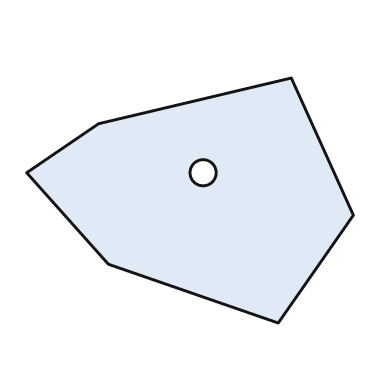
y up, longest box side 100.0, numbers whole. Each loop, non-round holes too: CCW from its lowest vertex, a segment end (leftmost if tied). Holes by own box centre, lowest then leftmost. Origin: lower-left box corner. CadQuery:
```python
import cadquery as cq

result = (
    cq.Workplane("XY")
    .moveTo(77.0, 0.0)
    .lineTo(100.0, 33.0)
    .lineTo(81.0, 75.0)
    .lineTo(22.0, 61.0)
    .lineTo(0.0, 46.0)
    .lineTo(25.0, 18.0)
    .close()
    .moveTo(54.0, 46.0)
    .circle(4.0)
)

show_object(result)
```